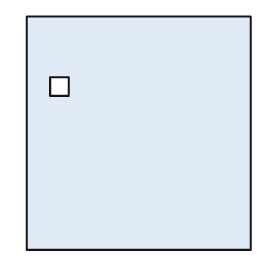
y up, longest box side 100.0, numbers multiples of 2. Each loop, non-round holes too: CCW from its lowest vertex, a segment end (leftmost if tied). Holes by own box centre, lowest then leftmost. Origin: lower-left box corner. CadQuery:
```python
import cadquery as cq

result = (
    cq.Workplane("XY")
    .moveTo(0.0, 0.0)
    .lineTo(96.0, 0.0)
    .lineTo(96.0, 100.0)
    .lineTo(0.0, 100.0)
    .close()
    .moveTo(10.0, 66.0)
    .lineTo(18.0, 66.0)
    .lineTo(18.0, 74.0)
    .lineTo(10.0, 74.0)
    .close()
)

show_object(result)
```